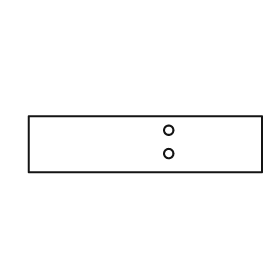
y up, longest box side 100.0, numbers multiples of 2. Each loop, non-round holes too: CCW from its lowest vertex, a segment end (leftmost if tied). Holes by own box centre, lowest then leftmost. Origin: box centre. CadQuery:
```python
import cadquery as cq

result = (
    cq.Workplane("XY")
    .moveTo(-50.0, -12.0)
    .lineTo(50.0, -12.0)
    .lineTo(50.0, 12.0)
    .lineTo(-50.0, 12.0)
    .close()
    .moveTo(10.0, -4.0)
    .circle(2.0)
    .moveTo(10.0, 6.0)
    .circle(2.0)
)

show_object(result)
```